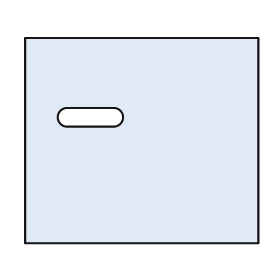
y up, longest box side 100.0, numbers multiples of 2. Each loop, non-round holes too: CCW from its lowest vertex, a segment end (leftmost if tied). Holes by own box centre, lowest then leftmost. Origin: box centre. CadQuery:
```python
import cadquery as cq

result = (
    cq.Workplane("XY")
    .moveTo(-50.0, -44.0)
    .lineTo(50.0, -44.0)
    .lineTo(50.0, 44.0)
    .lineTo(-50.0, 44.0)
    .close()
    .moveTo(-32.0, 6.0)
    .lineTo(-12.0, 6.0)
    .threePointArc((-8.0, 10.0), (-12.0, 14.0))
    .lineTo(-32.0, 14.0)
    .threePointArc((-36.0, 10.0), (-32.0, 6.0))
    .close()
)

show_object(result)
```